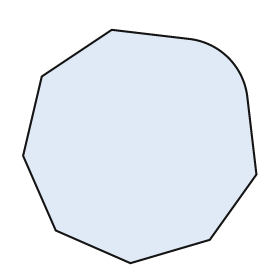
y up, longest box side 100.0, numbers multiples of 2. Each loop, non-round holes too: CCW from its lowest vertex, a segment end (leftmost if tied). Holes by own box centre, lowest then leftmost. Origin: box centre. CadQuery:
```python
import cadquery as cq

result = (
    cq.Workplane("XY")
    .moveTo(-4.0, -50.0)
    .lineTo(30.0, -40.0)
    .lineTo(50.0, -12.0)
    .lineTo(46.0, 22.0)
    .threePointArc((38.0, 38.0), (22.0, 46.0))
    .lineTo(-12.0, 50.0)
    .lineTo(-42.0, 30.0)
    .lineTo(-50.0, -4.0)
    .lineTo(-36.0, -36.0)
    .close()
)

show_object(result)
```